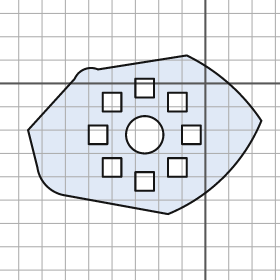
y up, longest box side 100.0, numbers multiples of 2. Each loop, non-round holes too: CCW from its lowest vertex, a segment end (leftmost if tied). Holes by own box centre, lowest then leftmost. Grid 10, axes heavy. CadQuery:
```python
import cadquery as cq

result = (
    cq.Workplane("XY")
    .moveTo(-16.0, -56.0)
    .threePointArc((8.0, -40.0), (24.0, -16.0))
    .threePointArc((10.0, 0.0), (-8.0, 12.0))
    .lineTo(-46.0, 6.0)
    .threePointArc((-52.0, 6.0), (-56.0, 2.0))
    .lineTo(-76.0, -20.0)
    .lineTo(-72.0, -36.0)
    .threePointArc((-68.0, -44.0), (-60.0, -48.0))
    .close()
    .moveTo(-30.0, -46.0)
    .lineTo(-22.0, -46.0)
    .lineTo(-22.0, -38.0)
    .lineTo(-30.0, -38.0)
    .close()
    .moveTo(-44.0, -40.0)
    .lineTo(-36.0, -40.0)
    .lineTo(-36.0, -32.0)
    .lineTo(-44.0, -32.0)
    .close()
    .moveTo(-16.0, -40.0)
    .lineTo(-8.0, -40.0)
    .lineTo(-8.0, -32.0)
    .lineTo(-16.0, -32.0)
    .close()
    .moveTo(-50.0, -26.0)
    .lineTo(-42.0, -26.0)
    .lineTo(-42.0, -18.0)
    .lineTo(-50.0, -18.0)
    .close()
    .moveTo(-26.0, -22.0)
    .circle(8.0)
    .moveTo(-10.0, -26.0)
    .lineTo(-2.0, -26.0)
    .lineTo(-2.0, -18.0)
    .lineTo(-10.0, -18.0)
    .close()
    .moveTo(-44.0, -12.0)
    .lineTo(-36.0, -12.0)
    .lineTo(-36.0, -4.0)
    .lineTo(-44.0, -4.0)
    .close()
    .moveTo(-16.0, -12.0)
    .lineTo(-8.0, -12.0)
    .lineTo(-8.0, -4.0)
    .lineTo(-16.0, -4.0)
    .close()
    .moveTo(-30.0, -6.0)
    .lineTo(-22.0, -6.0)
    .lineTo(-22.0, 2.0)
    .lineTo(-30.0, 2.0)
    .close()
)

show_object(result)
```